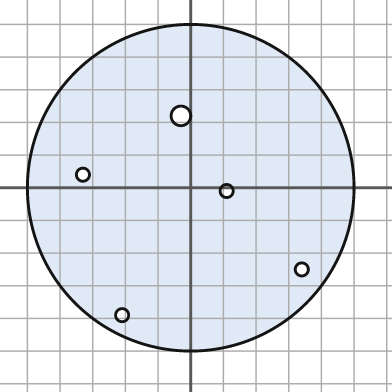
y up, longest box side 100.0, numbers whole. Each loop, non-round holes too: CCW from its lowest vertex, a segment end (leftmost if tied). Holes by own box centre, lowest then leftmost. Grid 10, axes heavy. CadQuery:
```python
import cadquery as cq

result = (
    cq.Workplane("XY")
    .moveTo(0.0, 0.0)
    .circle(50.0)
    .moveTo(-21.0, -39.0)
    .circle(2.0)
    .moveTo(34.0, -25.0)
    .circle(2.0)
    .moveTo(11.0, -1.0)
    .circle(2.0)
    .moveTo(-33.0, 4.0)
    .circle(2.0)
    .moveTo(-3.0, 22.0)
    .circle(3.0)
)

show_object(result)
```